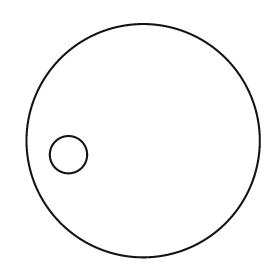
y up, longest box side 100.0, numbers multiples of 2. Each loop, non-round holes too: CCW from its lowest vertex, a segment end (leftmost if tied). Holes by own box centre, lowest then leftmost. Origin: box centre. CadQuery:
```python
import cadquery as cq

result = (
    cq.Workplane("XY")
    .moveTo(0.0, 0.0)
    .circle(50.0)
    .moveTo(-32.0, -6.0)
    .circle(8.0)
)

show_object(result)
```